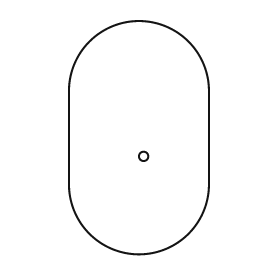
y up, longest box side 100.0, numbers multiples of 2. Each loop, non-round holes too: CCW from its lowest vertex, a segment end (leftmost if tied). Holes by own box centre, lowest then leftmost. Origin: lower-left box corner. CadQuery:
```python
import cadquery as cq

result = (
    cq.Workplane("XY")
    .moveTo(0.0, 30.0)
    .threePointArc((30.0, 0.0), (60.0, 30.0))
    .lineTo(60.0, 70.0)
    .threePointArc((30.0, 100.0), (0.0, 70.0))
    .close()
    .moveTo(32.0, 42.0)
    .circle(2.0)
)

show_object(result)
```